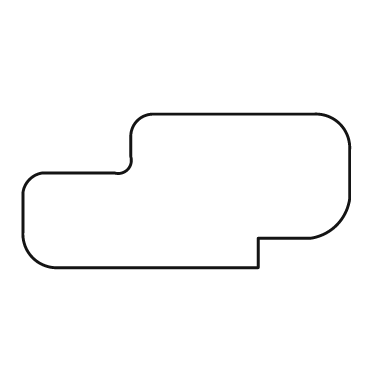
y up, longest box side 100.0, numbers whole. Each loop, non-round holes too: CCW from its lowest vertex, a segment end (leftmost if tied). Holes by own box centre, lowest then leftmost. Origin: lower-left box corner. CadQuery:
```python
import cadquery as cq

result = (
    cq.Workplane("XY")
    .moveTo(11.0, 0.0)
    .lineTo(72.0, 0.0)
    .lineTo(72.0, 9.0)
    .lineTo(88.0, 9.0)
    .threePointArc((96.0, 13.0), (100.0, 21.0))
    .lineTo(100.0, 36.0)
    .threePointArc((97.0, 44.0), (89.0, 47.0))
    .lineTo(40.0, 47.0)
    .threePointArc((35.0, 45.0), (33.0, 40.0))
    .lineTo(33.0, 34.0)
    .threePointArc((32.0, 30.0), (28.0, 29.0))
    .lineTo(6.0, 29.0)
    .threePointArc((2.0, 27.0), (0.0, 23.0))
    .lineTo(0.0, 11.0)
    .threePointArc((3.0, 3.0), (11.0, 0.0))
    .close()
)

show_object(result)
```